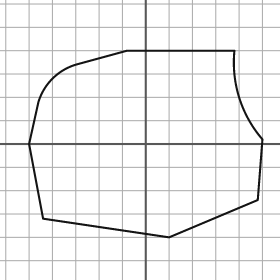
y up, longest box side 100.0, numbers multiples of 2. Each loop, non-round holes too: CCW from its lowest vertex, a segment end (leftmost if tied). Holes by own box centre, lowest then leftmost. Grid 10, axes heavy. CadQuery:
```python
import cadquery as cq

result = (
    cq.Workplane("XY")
    .moveTo(10.0, -40.0)
    .lineTo(48.0, -24.0)
    .lineTo(50.0, 2.0)
    .threePointArc((40.0, 20.0), (38.0, 40.0))
    .lineTo(-8.0, 40.0)
    .lineTo(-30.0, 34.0)
    .threePointArc((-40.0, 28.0), (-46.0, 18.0))
    .lineTo(-50.0, 0.0)
    .lineTo(-44.0, -32.0)
    .close()
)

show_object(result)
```